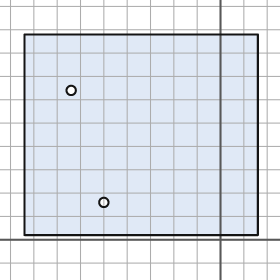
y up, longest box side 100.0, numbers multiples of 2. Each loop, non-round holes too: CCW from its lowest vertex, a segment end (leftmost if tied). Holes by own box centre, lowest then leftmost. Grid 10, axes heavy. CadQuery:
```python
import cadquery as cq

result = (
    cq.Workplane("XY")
    .moveTo(-84.0, 2.0)
    .lineTo(16.0, 2.0)
    .lineTo(16.0, 88.0)
    .lineTo(-84.0, 88.0)
    .close()
    .moveTo(-50.0, 16.0)
    .circle(2.0)
    .moveTo(-64.0, 64.0)
    .circle(2.0)
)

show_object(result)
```